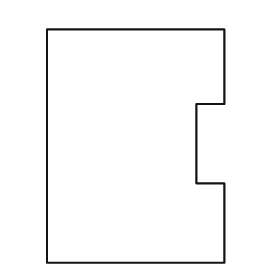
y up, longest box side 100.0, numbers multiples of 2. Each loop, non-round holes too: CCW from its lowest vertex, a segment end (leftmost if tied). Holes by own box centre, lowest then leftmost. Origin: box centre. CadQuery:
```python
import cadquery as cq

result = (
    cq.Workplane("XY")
    .moveTo(-38.0, -50.0)
    .lineTo(38.0, -50.0)
    .lineTo(38.0, -16.0)
    .lineTo(26.0, -16.0)
    .lineTo(26.0, 18.0)
    .lineTo(38.0, 18.0)
    .lineTo(38.0, 50.0)
    .lineTo(-38.0, 50.0)
    .close()
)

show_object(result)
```